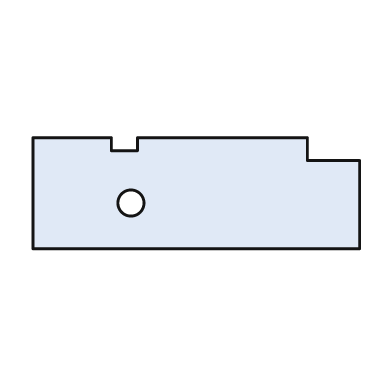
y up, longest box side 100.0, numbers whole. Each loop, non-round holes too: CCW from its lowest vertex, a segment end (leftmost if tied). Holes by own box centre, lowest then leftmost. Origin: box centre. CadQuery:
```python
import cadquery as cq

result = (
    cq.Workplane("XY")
    .moveTo(-50.0, -17.0)
    .lineTo(50.0, -17.0)
    .lineTo(50.0, 10.0)
    .lineTo(34.0, 10.0)
    .lineTo(34.0, 17.0)
    .lineTo(-18.0, 17.0)
    .lineTo(-18.0, 13.0)
    .lineTo(-26.0, 13.0)
    .lineTo(-26.0, 17.0)
    .lineTo(-50.0, 17.0)
    .close()
    .moveTo(-20.0, -3.0)
    .circle(4.0)
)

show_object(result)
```